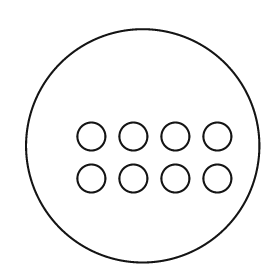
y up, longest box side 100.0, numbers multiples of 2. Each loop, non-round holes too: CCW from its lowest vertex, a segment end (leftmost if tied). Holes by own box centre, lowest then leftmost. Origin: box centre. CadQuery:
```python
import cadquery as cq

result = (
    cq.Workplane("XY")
    .moveTo(0.0, 0.0)
    .circle(50.0)
    .moveTo(-22.0, -14.0)
    .circle(6.0)
    .moveTo(-4.0, -14.0)
    .circle(6.0)
    .moveTo(14.0, -14.0)
    .circle(6.0)
    .moveTo(32.0, -14.0)
    .circle(6.0)
    .moveTo(-22.0, 4.0)
    .circle(6.0)
    .moveTo(-4.0, 4.0)
    .circle(6.0)
    .moveTo(14.0, 4.0)
    .circle(6.0)
    .moveTo(32.0, 4.0)
    .circle(6.0)
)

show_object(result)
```